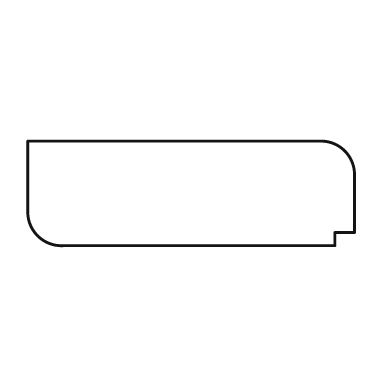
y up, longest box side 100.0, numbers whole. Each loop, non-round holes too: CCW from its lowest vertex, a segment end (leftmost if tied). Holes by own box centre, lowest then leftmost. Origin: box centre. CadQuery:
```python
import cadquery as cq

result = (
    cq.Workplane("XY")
    .moveTo(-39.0, -16.0)
    .lineTo(44.0, -16.0)
    .lineTo(44.0, -12.0)
    .lineTo(50.0, -12.0)
    .lineTo(50.0, 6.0)
    .threePointArc((47.0, 13.0), (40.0, 16.0))
    .lineTo(-50.0, 16.0)
    .lineTo(-50.0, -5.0)
    .threePointArc((-47.0, -13.0), (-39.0, -16.0))
    .close()
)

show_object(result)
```